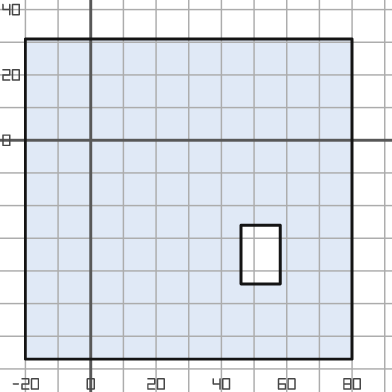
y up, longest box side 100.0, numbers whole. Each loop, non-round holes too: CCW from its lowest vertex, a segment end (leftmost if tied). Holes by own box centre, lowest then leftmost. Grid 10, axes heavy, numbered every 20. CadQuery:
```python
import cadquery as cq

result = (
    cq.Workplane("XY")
    .moveTo(-20.0, -67.0)
    .lineTo(80.0, -67.0)
    .lineTo(80.0, 31.0)
    .lineTo(-20.0, 31.0)
    .close()
    .moveTo(46.0, -44.0)
    .lineTo(58.0, -44.0)
    .lineTo(58.0, -26.0)
    .lineTo(46.0, -26.0)
    .close()
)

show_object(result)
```